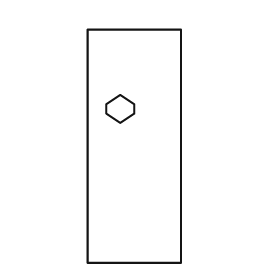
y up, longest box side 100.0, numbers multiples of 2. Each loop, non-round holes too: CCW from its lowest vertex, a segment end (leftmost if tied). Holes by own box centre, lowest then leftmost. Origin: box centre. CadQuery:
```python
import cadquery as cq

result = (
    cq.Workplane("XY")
    .moveTo(-20.0, -50.0)
    .lineTo(20.0, -50.0)
    .lineTo(20.0, 50.0)
    .lineTo(-20.0, 50.0)
    .close()
    .moveTo(-6.0, 10.0)
    .lineTo(0.0, 14.0)
    .lineTo(0.0, 18.0)
    .lineTo(-6.0, 22.0)
    .lineTo(-12.0, 18.0)
    .lineTo(-12.0, 14.0)
    .close()
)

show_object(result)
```